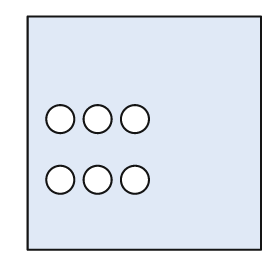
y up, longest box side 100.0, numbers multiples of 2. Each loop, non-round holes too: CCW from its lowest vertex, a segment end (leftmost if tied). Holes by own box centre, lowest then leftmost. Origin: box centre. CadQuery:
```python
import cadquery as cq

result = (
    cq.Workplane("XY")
    .moveTo(-50.0, -50.0)
    .lineTo(50.0, -50.0)
    .lineTo(50.0, 50.0)
    .lineTo(-50.0, 50.0)
    .close()
    .moveTo(-36.0, -20.0)
    .circle(6.0)
    .moveTo(-20.0, -20.0)
    .circle(6.0)
    .moveTo(-4.0, -20.0)
    .circle(6.0)
    .moveTo(-36.0, 6.0)
    .circle(6.0)
    .moveTo(-20.0, 6.0)
    .circle(6.0)
    .moveTo(-4.0, 6.0)
    .circle(6.0)
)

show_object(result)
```